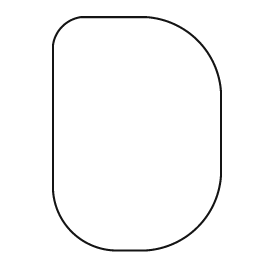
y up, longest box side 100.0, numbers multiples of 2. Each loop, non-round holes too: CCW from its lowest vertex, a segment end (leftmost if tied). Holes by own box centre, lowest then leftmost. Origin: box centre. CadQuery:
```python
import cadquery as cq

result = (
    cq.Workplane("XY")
    .moveTo(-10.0, -50.0)
    .lineTo(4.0, -50.0)
    .threePointArc((26.0, -40.0), (36.0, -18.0))
    .lineTo(36.0, 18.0)
    .threePointArc((26.0, 40.0), (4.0, 50.0))
    .lineTo(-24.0, 50.0)
    .threePointArc((-32.0, 46.0), (-36.0, 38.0))
    .lineTo(-36.0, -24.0)
    .threePointArc((-28.0, -42.0), (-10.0, -50.0))
    .close()
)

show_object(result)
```